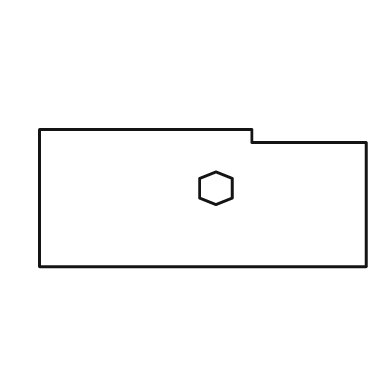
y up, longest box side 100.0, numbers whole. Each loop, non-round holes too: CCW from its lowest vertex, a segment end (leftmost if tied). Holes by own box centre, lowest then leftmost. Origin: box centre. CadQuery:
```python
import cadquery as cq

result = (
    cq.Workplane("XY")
    .moveTo(-50.0, -21.0)
    .lineTo(50.0, -21.0)
    .lineTo(50.0, 17.0)
    .lineTo(15.0, 17.0)
    .lineTo(15.0, 21.0)
    .lineTo(-50.0, 21.0)
    .close()
    .moveTo(4.0, -2.0)
    .lineTo(9.0, 0.0)
    .lineTo(9.0, 6.0)
    .lineTo(4.0, 8.0)
    .lineTo(-1.0, 6.0)
    .lineTo(-1.0, 0.0)
    .close()
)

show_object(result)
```